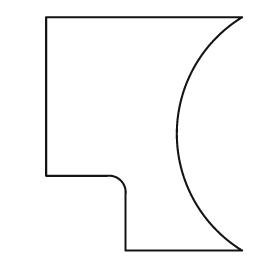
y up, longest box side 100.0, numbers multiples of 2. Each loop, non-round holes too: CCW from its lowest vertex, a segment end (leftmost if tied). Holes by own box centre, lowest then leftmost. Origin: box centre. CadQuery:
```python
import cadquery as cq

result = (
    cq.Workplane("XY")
    .moveTo(-8.0, -50.0)
    .lineTo(42.0, -50.0)
    .threePointArc((14.0, 0.0), (42.0, 50.0))
    .lineTo(-42.0, 50.0)
    .lineTo(-42.0, -18.0)
    .lineTo(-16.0, -18.0)
    .threePointArc((-10.0, -20.0), (-8.0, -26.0))
    .close()
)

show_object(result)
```